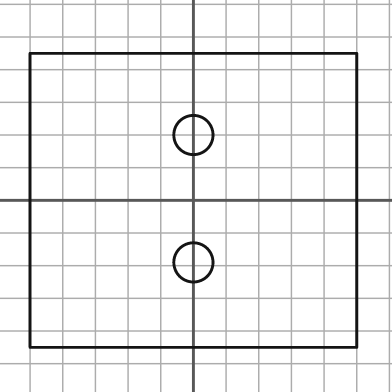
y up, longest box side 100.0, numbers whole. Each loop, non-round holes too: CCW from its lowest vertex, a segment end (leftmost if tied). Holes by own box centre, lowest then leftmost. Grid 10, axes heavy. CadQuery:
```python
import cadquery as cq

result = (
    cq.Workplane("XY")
    .moveTo(-50.0, -45.0)
    .lineTo(50.0, -45.0)
    .lineTo(50.0, 45.0)
    .lineTo(-50.0, 45.0)
    .close()
    .moveTo(0.0, -19.0)
    .circle(6.0)
    .moveTo(0.0, 20.0)
    .circle(6.0)
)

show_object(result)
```